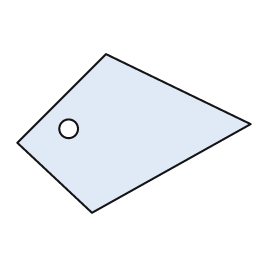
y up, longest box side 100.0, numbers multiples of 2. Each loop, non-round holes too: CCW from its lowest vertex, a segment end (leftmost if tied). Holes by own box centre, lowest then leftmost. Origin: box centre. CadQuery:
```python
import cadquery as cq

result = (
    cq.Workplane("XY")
    .moveTo(-18.0, -34.0)
    .lineTo(50.0, 4.0)
    .lineTo(-12.0, 34.0)
    .lineTo(-50.0, -4.0)
    .close()
    .moveTo(-28.0, 2.0)
    .circle(4.0)
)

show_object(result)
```